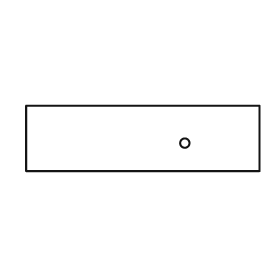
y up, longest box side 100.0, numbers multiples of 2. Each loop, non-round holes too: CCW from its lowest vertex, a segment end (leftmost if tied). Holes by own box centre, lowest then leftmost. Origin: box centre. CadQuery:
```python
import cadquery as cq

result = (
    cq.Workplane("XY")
    .moveTo(-50.0, -14.0)
    .lineTo(50.0, -14.0)
    .lineTo(50.0, 14.0)
    .lineTo(-50.0, 14.0)
    .close()
    .moveTo(18.0, -2.0)
    .circle(2.0)
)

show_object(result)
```